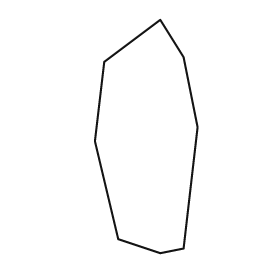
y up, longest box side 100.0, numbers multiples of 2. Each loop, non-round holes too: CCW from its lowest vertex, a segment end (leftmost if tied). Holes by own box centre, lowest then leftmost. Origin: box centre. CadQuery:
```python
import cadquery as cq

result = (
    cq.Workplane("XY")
    .moveTo(6.0, -50.0)
    .lineTo(16.0, -48.0)
    .lineTo(22.0, 4.0)
    .lineTo(16.0, 34.0)
    .lineTo(6.0, 50.0)
    .lineTo(-18.0, 32.0)
    .lineTo(-22.0, -2.0)
    .lineTo(-12.0, -44.0)
    .close()
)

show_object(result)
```